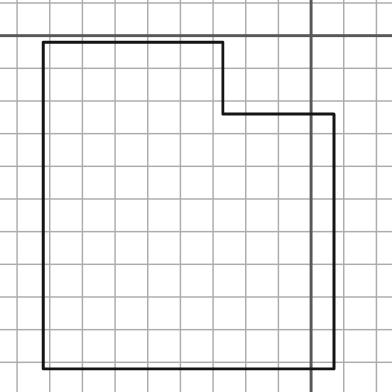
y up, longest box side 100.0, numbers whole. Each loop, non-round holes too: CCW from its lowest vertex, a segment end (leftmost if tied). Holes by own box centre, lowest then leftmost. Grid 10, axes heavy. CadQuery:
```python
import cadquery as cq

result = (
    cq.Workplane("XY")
    .moveTo(-82.0, -102.0)
    .lineTo(7.0, -102.0)
    .lineTo(7.0, -24.0)
    .lineTo(-27.0, -24.0)
    .lineTo(-27.0, -2.0)
    .lineTo(-82.0, -2.0)
    .close()
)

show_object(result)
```